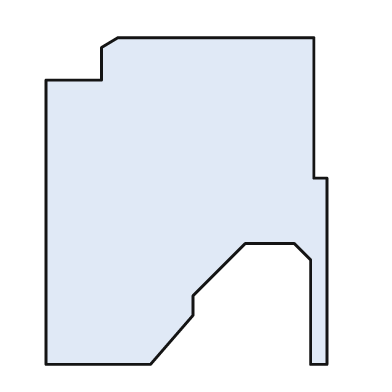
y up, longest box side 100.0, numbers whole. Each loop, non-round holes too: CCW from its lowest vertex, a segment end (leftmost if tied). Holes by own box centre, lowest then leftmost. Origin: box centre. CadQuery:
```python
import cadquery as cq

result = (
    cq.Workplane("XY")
    .moveTo(-43.0, -50.0)
    .lineTo(-11.0, -50.0)
    .lineTo(2.0, -35.0)
    .lineTo(2.0, -29.0)
    .lineTo(18.0, -13.0)
    .lineTo(33.0, -13.0)
    .lineTo(38.0, -18.0)
    .lineTo(38.0, -50.0)
    .lineTo(43.0, -50.0)
    .lineTo(43.0, 7.0)
    .lineTo(39.0, 7.0)
    .lineTo(39.0, 50.0)
    .lineTo(-21.0, 50.0)
    .lineTo(-26.0, 47.0)
    .lineTo(-26.0, 37.0)
    .lineTo(-43.0, 37.0)
    .close()
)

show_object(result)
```